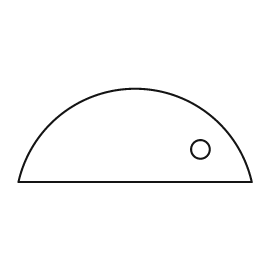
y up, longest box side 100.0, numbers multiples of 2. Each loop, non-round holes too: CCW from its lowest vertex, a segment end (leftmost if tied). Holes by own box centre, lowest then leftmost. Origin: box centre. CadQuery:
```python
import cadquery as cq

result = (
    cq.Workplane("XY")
    .moveTo(-50.0, -20.0)
    .lineTo(50.0, -20.0)
    .threePointArc((0.0, 20.0), (-50.0, -20.0))
    .close()
    .moveTo(28.0, -6.0)
    .circle(4.0)
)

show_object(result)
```